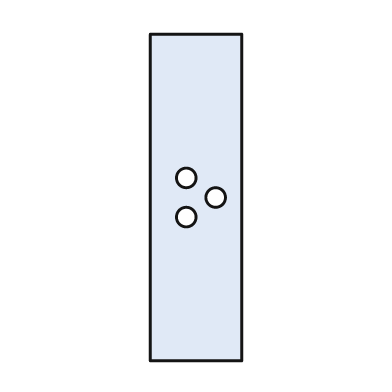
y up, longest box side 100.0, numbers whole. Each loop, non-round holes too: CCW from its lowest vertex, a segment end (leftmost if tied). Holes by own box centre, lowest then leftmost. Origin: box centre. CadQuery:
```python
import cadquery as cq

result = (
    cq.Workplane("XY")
    .moveTo(-14.0, -50.0)
    .lineTo(14.0, -50.0)
    .lineTo(14.0, 50.0)
    .lineTo(-14.0, 50.0)
    .close()
    .moveTo(-3.0, -6.0)
    .circle(3.0)
    .moveTo(6.0, 0.0)
    .circle(3.0)
    .moveTo(-3.0, 6.0)
    .circle(3.0)
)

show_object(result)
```